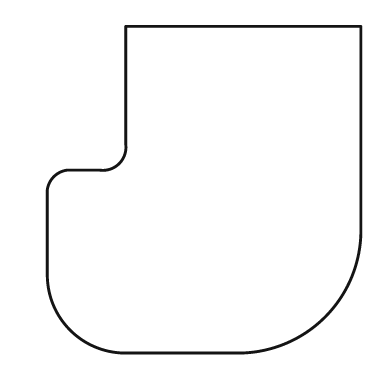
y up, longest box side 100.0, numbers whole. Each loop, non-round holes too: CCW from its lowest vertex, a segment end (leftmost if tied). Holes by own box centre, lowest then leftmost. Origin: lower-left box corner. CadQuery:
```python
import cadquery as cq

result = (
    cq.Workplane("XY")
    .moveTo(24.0, 0.0)
    .lineTo(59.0, 0.0)
    .threePointArc((85.0, 11.0), (96.0, 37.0))
    .lineTo(96.0, 100.0)
    .lineTo(24.0, 100.0)
    .lineTo(24.0, 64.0)
    .threePointArc((22.0, 58.0), (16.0, 56.0))
    .lineTo(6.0, 56.0)
    .threePointArc((2.0, 54.0), (0.0, 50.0))
    .lineTo(0.0, 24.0)
    .threePointArc((7.0, 7.0), (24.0, 0.0))
    .close()
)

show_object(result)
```